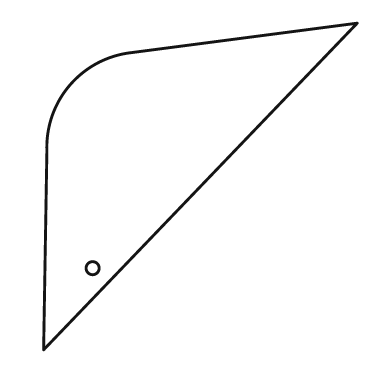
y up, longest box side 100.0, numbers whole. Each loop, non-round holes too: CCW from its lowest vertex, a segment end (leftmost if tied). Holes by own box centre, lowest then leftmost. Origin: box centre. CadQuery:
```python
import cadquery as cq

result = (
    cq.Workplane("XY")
    .moveTo(-48.0, -50.0)
    .lineTo(48.0, 50.0)
    .lineTo(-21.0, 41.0)
    .threePointArc((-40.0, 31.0), (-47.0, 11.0))
    .close()
    .moveTo(-33.0, -25.0)
    .circle(2.0)
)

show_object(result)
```